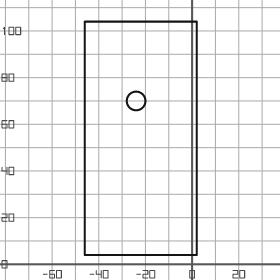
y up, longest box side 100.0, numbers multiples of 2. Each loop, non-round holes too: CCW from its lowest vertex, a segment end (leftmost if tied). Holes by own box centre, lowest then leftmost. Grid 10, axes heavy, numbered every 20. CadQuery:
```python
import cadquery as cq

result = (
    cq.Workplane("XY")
    .moveTo(-46.0, 4.0)
    .lineTo(2.0, 4.0)
    .lineTo(2.0, 104.0)
    .lineTo(-46.0, 104.0)
    .close()
    .moveTo(-24.0, 70.0)
    .circle(4.0)
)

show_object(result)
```